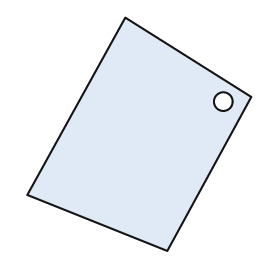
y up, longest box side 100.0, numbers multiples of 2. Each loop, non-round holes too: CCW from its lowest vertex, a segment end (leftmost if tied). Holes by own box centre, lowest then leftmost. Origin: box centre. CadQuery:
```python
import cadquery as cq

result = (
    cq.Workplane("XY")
    .moveTo(12.0, -50.0)
    .lineTo(48.0, 16.0)
    .lineTo(-6.0, 50.0)
    .lineTo(-48.0, -26.0)
    .close()
    .moveTo(36.0, 14.0)
    .circle(4.0)
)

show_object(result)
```